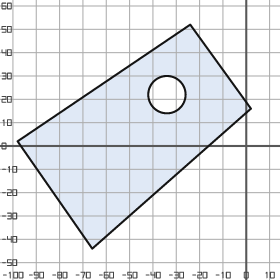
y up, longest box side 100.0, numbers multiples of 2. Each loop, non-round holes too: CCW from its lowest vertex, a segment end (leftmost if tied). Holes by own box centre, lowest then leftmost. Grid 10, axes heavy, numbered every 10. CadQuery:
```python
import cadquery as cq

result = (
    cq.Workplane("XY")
    .moveTo(-66.0, -44.0)
    .lineTo(2.0, 16.0)
    .lineTo(-24.0, 52.0)
    .lineTo(-98.0, 2.0)
    .close()
    .moveTo(-34.0, 22.0)
    .circle(8.0)
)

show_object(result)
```